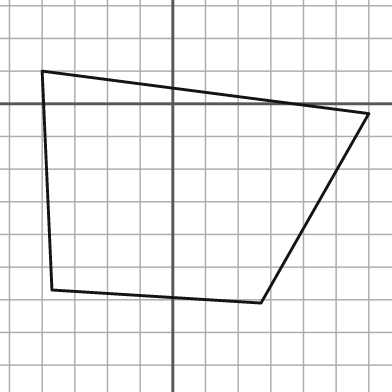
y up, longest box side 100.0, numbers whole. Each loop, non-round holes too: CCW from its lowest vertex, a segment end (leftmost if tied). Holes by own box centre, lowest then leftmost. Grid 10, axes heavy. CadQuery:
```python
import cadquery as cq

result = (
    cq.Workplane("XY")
    .moveTo(27.0, -61.0)
    .lineTo(60.0, -3.0)
    .lineTo(-40.0, 10.0)
    .lineTo(-37.0, -57.0)
    .close()
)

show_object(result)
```